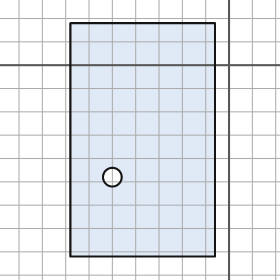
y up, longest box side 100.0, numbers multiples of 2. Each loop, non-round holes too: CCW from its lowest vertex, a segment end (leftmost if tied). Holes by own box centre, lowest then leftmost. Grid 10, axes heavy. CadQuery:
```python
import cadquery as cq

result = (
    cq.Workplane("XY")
    .moveTo(-68.0, -82.0)
    .lineTo(-6.0, -82.0)
    .lineTo(-6.0, 18.0)
    .lineTo(-68.0, 18.0)
    .close()
    .moveTo(-50.0, -48.0)
    .circle(4.0)
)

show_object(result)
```